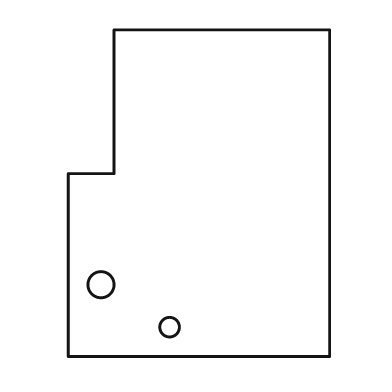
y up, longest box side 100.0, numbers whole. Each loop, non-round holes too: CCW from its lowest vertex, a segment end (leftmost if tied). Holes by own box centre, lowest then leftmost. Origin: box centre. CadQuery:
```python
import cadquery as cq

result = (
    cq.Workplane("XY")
    .moveTo(-40.0, -50.0)
    .lineTo(40.0, -50.0)
    .lineTo(40.0, 50.0)
    .lineTo(-26.0, 50.0)
    .lineTo(-26.0, 6.0)
    .lineTo(-40.0, 6.0)
    .close()
    .moveTo(-9.0, -41.0)
    .circle(3.0)
    .moveTo(-30.0, -28.0)
    .circle(4.0)
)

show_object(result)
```